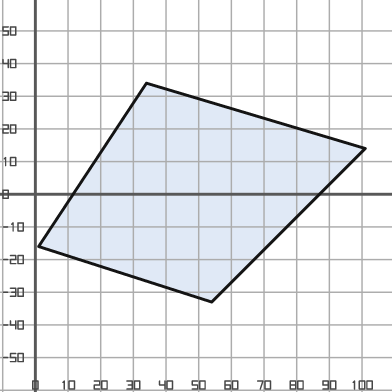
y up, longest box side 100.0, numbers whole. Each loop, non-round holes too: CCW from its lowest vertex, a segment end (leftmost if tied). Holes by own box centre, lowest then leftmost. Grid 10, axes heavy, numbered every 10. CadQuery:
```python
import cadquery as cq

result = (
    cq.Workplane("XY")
    .moveTo(54.0, -33.0)
    .lineTo(101.0, 14.0)
    .lineTo(34.0, 34.0)
    .lineTo(1.0, -16.0)
    .close()
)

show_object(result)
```